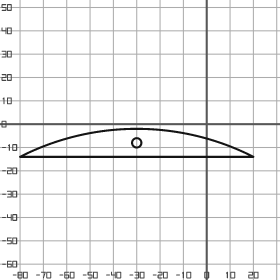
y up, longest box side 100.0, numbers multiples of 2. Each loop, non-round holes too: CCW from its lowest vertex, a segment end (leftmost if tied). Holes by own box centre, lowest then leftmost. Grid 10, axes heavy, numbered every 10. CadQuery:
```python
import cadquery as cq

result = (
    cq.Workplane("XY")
    .moveTo(-80.0, -14.0)
    .lineTo(20.0, -14.0)
    .threePointArc((-30.0, -2.0), (-80.0, -14.0))
    .close()
    .moveTo(-30.0, -8.0)
    .circle(2.0)
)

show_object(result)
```